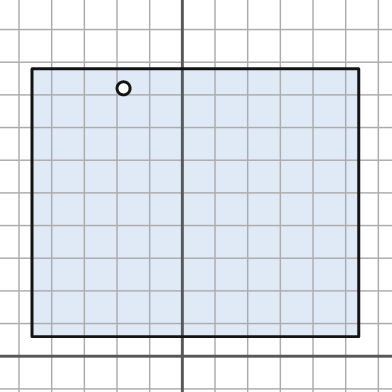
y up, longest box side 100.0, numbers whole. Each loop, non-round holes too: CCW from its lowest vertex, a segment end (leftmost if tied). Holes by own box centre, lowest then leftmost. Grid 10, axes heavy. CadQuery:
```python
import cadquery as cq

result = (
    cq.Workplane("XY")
    .moveTo(-46.0, 6.0)
    .lineTo(54.0, 6.0)
    .lineTo(54.0, 88.0)
    .lineTo(-46.0, 88.0)
    .close()
    .moveTo(-18.0, 82.0)
    .circle(2.0)
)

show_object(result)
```